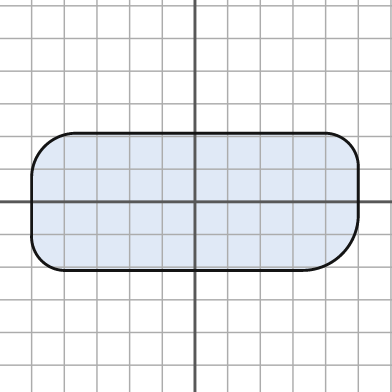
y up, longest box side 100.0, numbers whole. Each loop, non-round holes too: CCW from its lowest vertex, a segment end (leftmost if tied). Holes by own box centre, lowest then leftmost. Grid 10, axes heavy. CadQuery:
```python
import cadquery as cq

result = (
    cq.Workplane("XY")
    .moveTo(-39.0, -21.0)
    .lineTo(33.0, -21.0)
    .threePointArc((45.0, -16.0), (50.0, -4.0))
    .lineTo(50.0, 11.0)
    .threePointArc((47.0, 18.0), (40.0, 21.0))
    .lineTo(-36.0, 21.0)
    .threePointArc((-46.0, 17.0), (-50.0, 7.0))
    .lineTo(-50.0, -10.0)
    .threePointArc((-47.0, -18.0), (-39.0, -21.0))
    .close()
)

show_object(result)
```